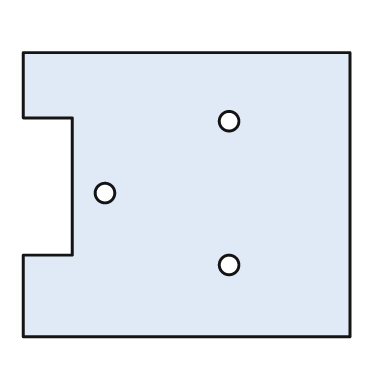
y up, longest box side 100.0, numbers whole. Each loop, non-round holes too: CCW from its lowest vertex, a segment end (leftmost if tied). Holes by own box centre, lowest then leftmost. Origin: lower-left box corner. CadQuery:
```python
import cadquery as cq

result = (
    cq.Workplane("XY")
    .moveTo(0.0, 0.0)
    .lineTo(100.0, 0.0)
    .lineTo(100.0, 87.0)
    .lineTo(0.0, 87.0)
    .lineTo(0.0, 67.0)
    .lineTo(15.0, 67.0)
    .lineTo(15.0, 25.0)
    .lineTo(0.0, 25.0)
    .close()
    .moveTo(63.0, 22.0)
    .circle(3.0)
    .moveTo(25.0, 44.0)
    .circle(3.0)
    .moveTo(63.0, 66.0)
    .circle(3.0)
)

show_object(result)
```